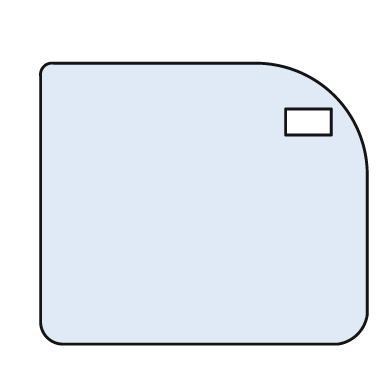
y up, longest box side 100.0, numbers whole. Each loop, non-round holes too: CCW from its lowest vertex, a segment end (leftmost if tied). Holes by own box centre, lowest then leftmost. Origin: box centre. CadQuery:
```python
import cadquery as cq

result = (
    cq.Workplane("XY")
    .moveTo(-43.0, -43.0)
    .lineTo(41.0, -43.0)
    .threePointArc((47.0, -40.0), (50.0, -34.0))
    .lineTo(50.0, 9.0)
    .threePointArc((40.0, 33.0), (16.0, 43.0))
    .lineTo(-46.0, 43.0)
    .threePointArc((-49.0, 42.0), (-50.0, 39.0))
    .lineTo(-50.0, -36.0)
    .threePointArc((-48.0, -41.0), (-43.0, -43.0))
    .close()
    .moveTo(25.0, 21.0)
    .lineTo(39.0, 21.0)
    .lineTo(39.0, 29.0)
    .lineTo(25.0, 29.0)
    .close()
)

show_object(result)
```